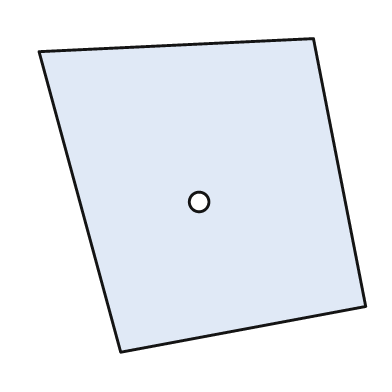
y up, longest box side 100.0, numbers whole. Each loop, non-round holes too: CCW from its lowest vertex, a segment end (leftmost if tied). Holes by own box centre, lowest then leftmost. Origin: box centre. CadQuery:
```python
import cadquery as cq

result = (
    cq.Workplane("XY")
    .moveTo(-25.0, -48.0)
    .lineTo(50.0, -34.0)
    .lineTo(34.0, 48.0)
    .lineTo(-50.0, 44.0)
    .close()
    .moveTo(-1.0, -2.0)
    .circle(3.0)
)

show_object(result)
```